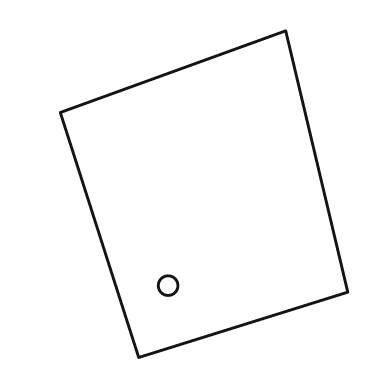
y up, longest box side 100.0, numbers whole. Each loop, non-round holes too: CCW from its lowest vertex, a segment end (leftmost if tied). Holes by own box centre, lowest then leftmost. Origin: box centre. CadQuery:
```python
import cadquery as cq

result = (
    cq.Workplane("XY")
    .moveTo(-20.0, -50.0)
    .lineTo(44.0, -30.0)
    .lineTo(25.0, 50.0)
    .lineTo(-44.0, 25.0)
    .close()
    .moveTo(-11.0, -28.0)
    .circle(3.0)
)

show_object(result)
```